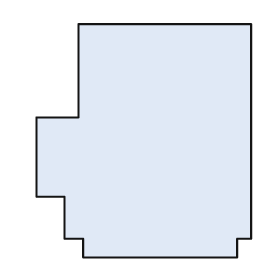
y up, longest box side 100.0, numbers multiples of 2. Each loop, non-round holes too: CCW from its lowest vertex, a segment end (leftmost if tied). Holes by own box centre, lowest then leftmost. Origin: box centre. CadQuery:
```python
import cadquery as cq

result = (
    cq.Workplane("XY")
    .moveTo(-26.0, -50.0)
    .lineTo(40.0, -50.0)
    .lineTo(40.0, -42.0)
    .lineTo(46.0, -42.0)
    .lineTo(46.0, 50.0)
    .lineTo(-28.0, 50.0)
    .lineTo(-28.0, 10.0)
    .lineTo(-46.0, 10.0)
    .lineTo(-46.0, -24.0)
    .lineTo(-34.0, -24.0)
    .lineTo(-34.0, -42.0)
    .lineTo(-26.0, -42.0)
    .close()
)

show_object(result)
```